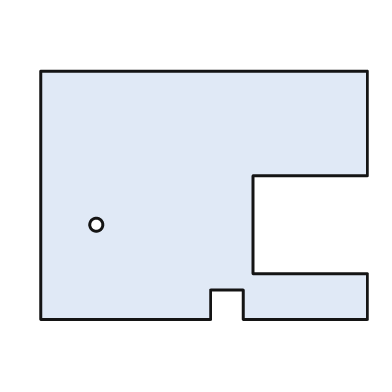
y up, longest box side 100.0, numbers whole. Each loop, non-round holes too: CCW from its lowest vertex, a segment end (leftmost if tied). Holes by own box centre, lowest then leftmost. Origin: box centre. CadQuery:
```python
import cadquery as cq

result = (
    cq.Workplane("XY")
    .moveTo(-50.0, -38.0)
    .lineTo(2.0, -38.0)
    .lineTo(2.0, -29.0)
    .lineTo(12.0, -29.0)
    .lineTo(12.0, -38.0)
    .lineTo(50.0, -38.0)
    .lineTo(50.0, -24.0)
    .lineTo(15.0, -24.0)
    .lineTo(15.0, 6.0)
    .lineTo(50.0, 6.0)
    .lineTo(50.0, 38.0)
    .lineTo(-50.0, 38.0)
    .close()
    .moveTo(-33.0, -9.0)
    .circle(2.0)
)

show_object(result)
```